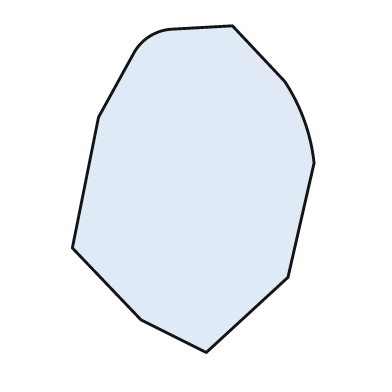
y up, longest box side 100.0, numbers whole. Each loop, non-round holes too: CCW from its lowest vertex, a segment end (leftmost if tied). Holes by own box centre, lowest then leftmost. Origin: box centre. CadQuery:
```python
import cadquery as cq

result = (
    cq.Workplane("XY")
    .moveTo(4.0, -50.0)
    .lineTo(29.0, -27.0)
    .lineTo(37.0, 8.0)
    .threePointArc((34.0, 21.0), (28.0, 33.0))
    .lineTo(12.0, 50.0)
    .lineTo(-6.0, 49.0)
    .threePointArc((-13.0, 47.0), (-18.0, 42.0))
    .lineTo(-29.0, 22.0)
    .lineTo(-37.0, -18.0)
    .lineTo(-16.0, -40.0)
    .close()
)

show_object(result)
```